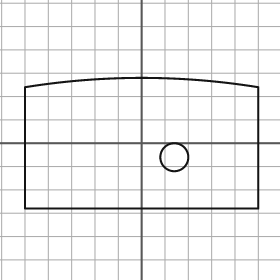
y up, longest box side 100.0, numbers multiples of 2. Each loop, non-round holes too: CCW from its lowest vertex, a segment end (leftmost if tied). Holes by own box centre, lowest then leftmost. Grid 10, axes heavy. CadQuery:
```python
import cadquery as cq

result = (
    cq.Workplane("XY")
    .moveTo(-50.0, -28.0)
    .lineTo(50.0, -28.0)
    .lineTo(50.0, 24.0)
    .threePointArc((0.0, 28.0), (-50.0, 24.0))
    .close()
    .moveTo(14.0, -6.0)
    .circle(6.0)
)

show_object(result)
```